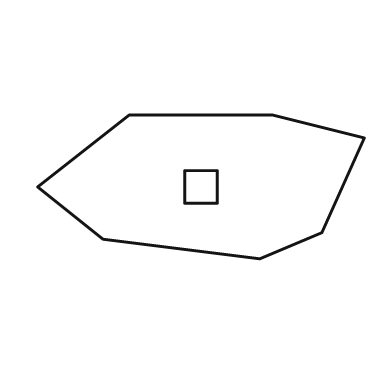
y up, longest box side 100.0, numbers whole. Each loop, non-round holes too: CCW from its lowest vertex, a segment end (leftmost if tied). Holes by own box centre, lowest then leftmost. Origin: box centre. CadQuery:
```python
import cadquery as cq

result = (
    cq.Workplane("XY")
    .moveTo(18.0, -22.0)
    .lineTo(37.0, -14.0)
    .lineTo(50.0, 15.0)
    .lineTo(22.0, 22.0)
    .lineTo(-22.0, 22.0)
    .lineTo(-50.0, 0.0)
    .lineTo(-30.0, -16.0)
    .close()
    .moveTo(-5.0, -5.0)
    .lineTo(5.0, -5.0)
    .lineTo(5.0, 5.0)
    .lineTo(-5.0, 5.0)
    .close()
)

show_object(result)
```